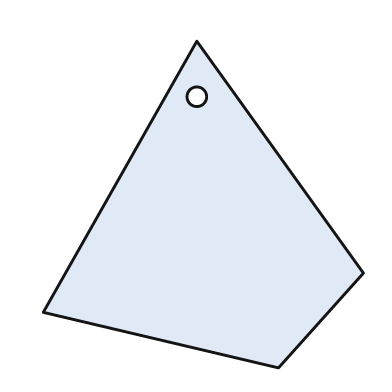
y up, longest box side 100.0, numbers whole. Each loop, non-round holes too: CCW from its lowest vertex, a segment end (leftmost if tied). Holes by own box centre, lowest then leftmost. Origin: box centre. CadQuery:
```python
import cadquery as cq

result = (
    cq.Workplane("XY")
    .moveTo(23.0, -50.0)
    .lineTo(49.0, -21.0)
    .lineTo(-2.0, 50.0)
    .lineTo(-49.0, -33.0)
    .close()
    .moveTo(-2.0, 33.0)
    .circle(3.0)
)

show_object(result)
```